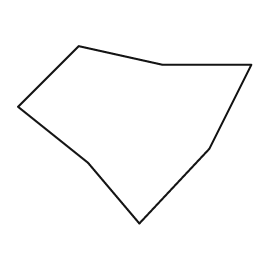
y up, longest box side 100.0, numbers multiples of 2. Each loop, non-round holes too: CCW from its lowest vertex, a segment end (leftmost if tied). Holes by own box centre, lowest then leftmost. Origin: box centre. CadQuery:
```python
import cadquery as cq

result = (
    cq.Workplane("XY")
    .moveTo(2.0, -38.0)
    .lineTo(32.0, -6.0)
    .lineTo(50.0, 30.0)
    .lineTo(12.0, 30.0)
    .lineTo(-24.0, 38.0)
    .lineTo(-50.0, 12.0)
    .lineTo(-20.0, -12.0)
    .close()
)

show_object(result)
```